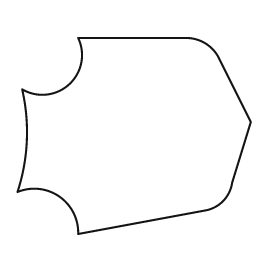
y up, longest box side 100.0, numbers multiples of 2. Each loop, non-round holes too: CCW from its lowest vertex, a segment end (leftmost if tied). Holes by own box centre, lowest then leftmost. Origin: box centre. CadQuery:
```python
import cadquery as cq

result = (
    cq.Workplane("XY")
    .moveTo(-24.0, -42.0)
    .lineTo(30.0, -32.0)
    .threePointArc((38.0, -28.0), (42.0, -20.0))
    .lineTo(50.0, 6.0)
    .lineTo(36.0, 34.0)
    .threePointArc((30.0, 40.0), (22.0, 42.0))
    .lineTo(-24.0, 42.0)
    .threePointArc((-28.0, 22.0), (-48.0, 20.0))
    .threePointArc((-46.0, -2.0), (-50.0, -24.0))
    .threePointArc((-32.0, -26.0), (-24.0, -42.0))
    .close()
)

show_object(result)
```